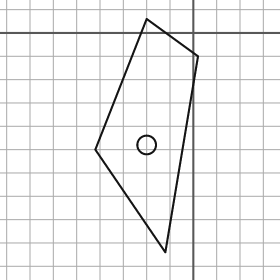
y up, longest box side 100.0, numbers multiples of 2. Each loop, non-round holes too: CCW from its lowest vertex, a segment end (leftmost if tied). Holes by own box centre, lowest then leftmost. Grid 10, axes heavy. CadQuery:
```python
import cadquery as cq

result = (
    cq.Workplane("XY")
    .moveTo(-12.0, -94.0)
    .lineTo(2.0, -10.0)
    .lineTo(-20.0, 6.0)
    .lineTo(-42.0, -50.0)
    .close()
    .moveTo(-20.0, -48.0)
    .circle(4.0)
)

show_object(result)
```